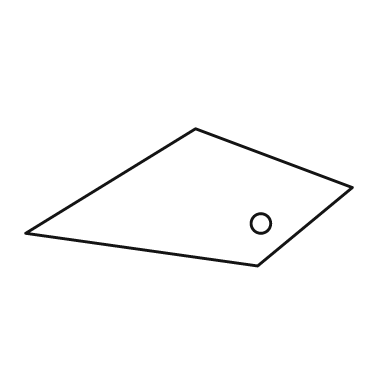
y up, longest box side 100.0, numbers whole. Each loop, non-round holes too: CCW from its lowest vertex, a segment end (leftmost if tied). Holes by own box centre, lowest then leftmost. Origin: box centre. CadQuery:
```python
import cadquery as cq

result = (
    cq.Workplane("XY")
    .moveTo(21.0, -21.0)
    .lineTo(50.0, 3.0)
    .lineTo(2.0, 21.0)
    .lineTo(-50.0, -11.0)
    .close()
    .moveTo(22.0, -8.0)
    .circle(3.0)
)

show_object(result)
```